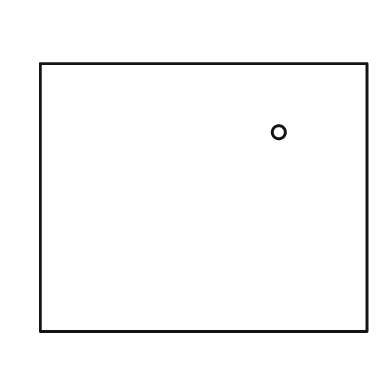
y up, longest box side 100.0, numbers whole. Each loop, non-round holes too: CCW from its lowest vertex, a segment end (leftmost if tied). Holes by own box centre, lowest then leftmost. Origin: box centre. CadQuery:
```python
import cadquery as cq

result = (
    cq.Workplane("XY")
    .moveTo(-50.0, -41.0)
    .lineTo(50.0, -41.0)
    .lineTo(50.0, 41.0)
    .lineTo(-50.0, 41.0)
    .close()
    .moveTo(23.0, 20.0)
    .circle(2.0)
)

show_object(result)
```